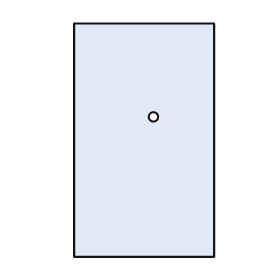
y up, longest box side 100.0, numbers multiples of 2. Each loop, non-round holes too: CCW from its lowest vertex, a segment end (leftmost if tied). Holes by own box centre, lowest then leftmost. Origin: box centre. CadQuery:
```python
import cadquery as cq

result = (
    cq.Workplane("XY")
    .moveTo(-30.0, -50.0)
    .lineTo(30.0, -50.0)
    .lineTo(30.0, 50.0)
    .lineTo(-30.0, 50.0)
    .close()
    .moveTo(4.0, 10.0)
    .circle(2.0)
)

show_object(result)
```